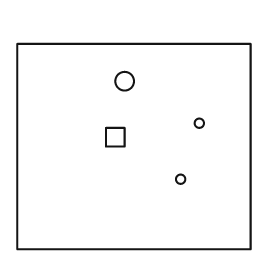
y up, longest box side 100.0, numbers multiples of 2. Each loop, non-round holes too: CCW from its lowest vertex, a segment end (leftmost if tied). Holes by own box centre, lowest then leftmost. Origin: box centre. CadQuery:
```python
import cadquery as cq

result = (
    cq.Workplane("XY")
    .moveTo(-50.0, -44.0)
    .lineTo(50.0, -44.0)
    .lineTo(50.0, 44.0)
    .lineTo(-50.0, 44.0)
    .close()
    .moveTo(20.0, -14.0)
    .circle(2.0)
    .moveTo(-12.0, 0.0)
    .lineTo(-4.0, 0.0)
    .lineTo(-4.0, 8.0)
    .lineTo(-12.0, 8.0)
    .close()
    .moveTo(28.0, 10.0)
    .circle(2.0)
    .moveTo(-4.0, 28.0)
    .circle(4.0)
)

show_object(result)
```